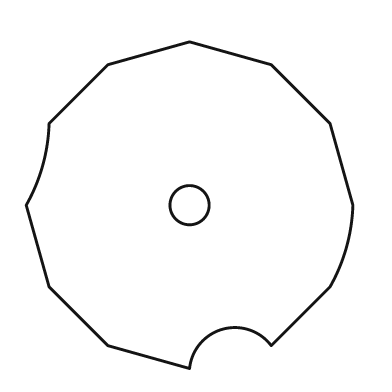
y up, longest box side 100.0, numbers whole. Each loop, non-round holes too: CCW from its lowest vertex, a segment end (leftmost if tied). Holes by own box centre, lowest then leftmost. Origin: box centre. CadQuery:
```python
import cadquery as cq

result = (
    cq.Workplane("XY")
    .moveTo(0.0, -50.0)
    .threePointArc((10.0, -38.0), (25.0, -43.0))
    .lineTo(43.0, -25.0)
    .threePointArc((48.0, -13.0), (50.0, 0.0))
    .lineTo(43.0, 25.0)
    .lineTo(25.0, 43.0)
    .lineTo(0.0, 50.0)
    .lineTo(-25.0, 43.0)
    .lineTo(-43.0, 25.0)
    .threePointArc((-45.0, 12.0), (-50.0, 0.0))
    .lineTo(-43.0, -25.0)
    .lineTo(-25.0, -43.0)
    .close()
    .moveTo(0.0, 0.0)
    .circle(6.0)
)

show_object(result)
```